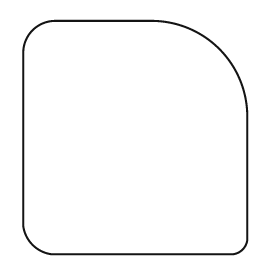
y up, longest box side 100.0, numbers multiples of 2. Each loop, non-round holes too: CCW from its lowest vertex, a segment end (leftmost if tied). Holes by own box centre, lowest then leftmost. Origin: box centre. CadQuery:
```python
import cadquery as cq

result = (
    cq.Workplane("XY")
    .moveTo(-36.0, -50.0)
    .lineTo(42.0, -50.0)
    .threePointArc((46.0, -48.0), (48.0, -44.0))
    .lineTo(48.0, 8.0)
    .threePointArc((36.0, 38.0), (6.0, 50.0))
    .lineTo(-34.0, 50.0)
    .threePointArc((-44.0, 46.0), (-48.0, 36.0))
    .lineTo(-48.0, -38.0)
    .threePointArc((-44.0, -46.0), (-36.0, -50.0))
    .close()
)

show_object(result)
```